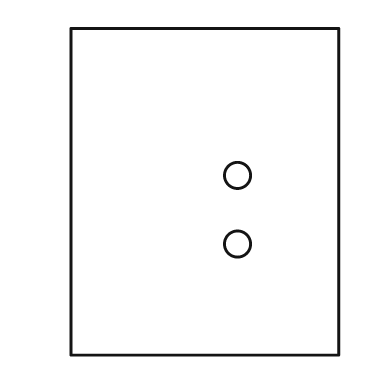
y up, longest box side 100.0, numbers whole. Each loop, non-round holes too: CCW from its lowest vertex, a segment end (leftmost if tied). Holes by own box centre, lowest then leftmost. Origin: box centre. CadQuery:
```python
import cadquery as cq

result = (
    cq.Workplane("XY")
    .moveTo(-41.0, -50.0)
    .lineTo(41.0, -50.0)
    .lineTo(41.0, 50.0)
    .lineTo(-41.0, 50.0)
    .close()
    .moveTo(10.0, -16.0)
    .circle(4.0)
    .moveTo(10.0, 5.0)
    .circle(4.0)
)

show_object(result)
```